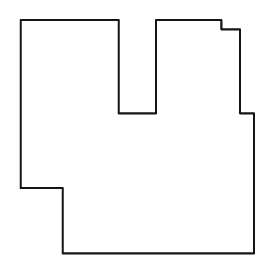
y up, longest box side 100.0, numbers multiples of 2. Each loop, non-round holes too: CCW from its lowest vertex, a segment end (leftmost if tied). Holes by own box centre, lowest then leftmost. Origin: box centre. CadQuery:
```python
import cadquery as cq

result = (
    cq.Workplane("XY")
    .moveTo(-32.0, -50.0)
    .lineTo(50.0, -50.0)
    .lineTo(50.0, 10.0)
    .lineTo(44.0, 10.0)
    .lineTo(44.0, 46.0)
    .lineTo(36.0, 46.0)
    .lineTo(36.0, 50.0)
    .lineTo(8.0, 50.0)
    .lineTo(8.0, 10.0)
    .lineTo(-8.0, 10.0)
    .lineTo(-8.0, 50.0)
    .lineTo(-50.0, 50.0)
    .lineTo(-50.0, -22.0)
    .lineTo(-32.0, -22.0)
    .close()
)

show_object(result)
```